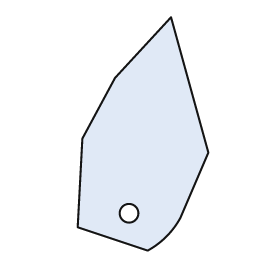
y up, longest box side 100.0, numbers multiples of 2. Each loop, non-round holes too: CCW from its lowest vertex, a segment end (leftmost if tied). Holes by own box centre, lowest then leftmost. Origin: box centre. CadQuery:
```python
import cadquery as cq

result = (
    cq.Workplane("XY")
    .moveTo(2.0, -50.0)
    .threePointArc((10.0, -44.0), (16.0, -36.0))
    .lineTo(28.0, -8.0)
    .lineTo(12.0, 50.0)
    .lineTo(-12.0, 24.0)
    .lineTo(-26.0, -2.0)
    .lineTo(-28.0, -40.0)
    .close()
    .moveTo(-6.0, -34.0)
    .circle(4.0)
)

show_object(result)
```